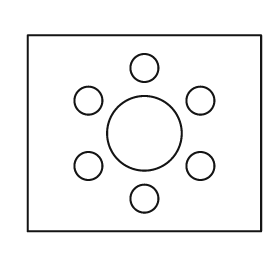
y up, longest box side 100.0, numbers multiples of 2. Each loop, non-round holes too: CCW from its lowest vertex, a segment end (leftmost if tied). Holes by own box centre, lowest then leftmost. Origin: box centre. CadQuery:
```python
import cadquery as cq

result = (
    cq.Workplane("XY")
    .moveTo(-50.0, -42.0)
    .lineTo(50.0, -42.0)
    .lineTo(50.0, 42.0)
    .lineTo(-50.0, 42.0)
    .close()
    .moveTo(0.0, -28.0)
    .circle(6.0)
    .moveTo(-24.0, -14.0)
    .circle(6.0)
    .moveTo(24.0, -14.0)
    .circle(6.0)
    .moveTo(0.0, 0.0)
    .circle(16.0)
    .moveTo(-24.0, 14.0)
    .circle(6.0)
    .moveTo(24.0, 14.0)
    .circle(6.0)
    .moveTo(0.0, 28.0)
    .circle(6.0)
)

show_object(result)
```